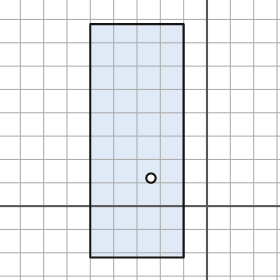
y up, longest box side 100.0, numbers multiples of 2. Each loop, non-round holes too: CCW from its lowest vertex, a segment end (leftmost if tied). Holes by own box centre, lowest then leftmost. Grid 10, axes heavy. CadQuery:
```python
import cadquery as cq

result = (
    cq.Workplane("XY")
    .moveTo(-50.0, -22.0)
    .lineTo(-10.0, -22.0)
    .lineTo(-10.0, 78.0)
    .lineTo(-50.0, 78.0)
    .close()
    .moveTo(-24.0, 12.0)
    .circle(2.0)
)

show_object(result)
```